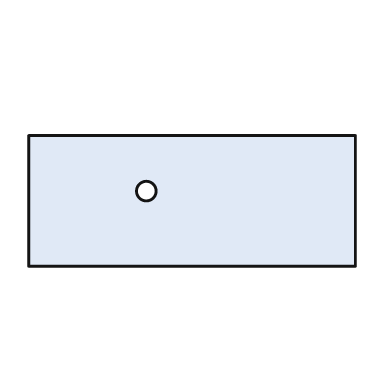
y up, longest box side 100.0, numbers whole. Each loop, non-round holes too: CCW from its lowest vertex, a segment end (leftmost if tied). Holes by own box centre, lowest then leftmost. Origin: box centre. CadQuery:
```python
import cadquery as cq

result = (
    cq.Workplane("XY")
    .moveTo(-50.0, -20.0)
    .lineTo(50.0, -20.0)
    .lineTo(50.0, 20.0)
    .lineTo(-50.0, 20.0)
    .close()
    .moveTo(-14.0, 3.0)
    .circle(3.0)
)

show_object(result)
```